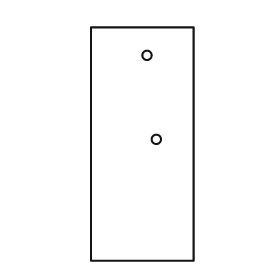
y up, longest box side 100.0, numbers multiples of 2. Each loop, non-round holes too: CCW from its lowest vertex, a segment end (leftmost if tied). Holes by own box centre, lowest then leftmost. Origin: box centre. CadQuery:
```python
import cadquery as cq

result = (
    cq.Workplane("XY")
    .moveTo(-22.0, -50.0)
    .lineTo(22.0, -50.0)
    .lineTo(22.0, 50.0)
    .lineTo(-22.0, 50.0)
    .close()
    .moveTo(6.0, 2.0)
    .circle(2.0)
    .moveTo(2.0, 38.0)
    .circle(2.0)
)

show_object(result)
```